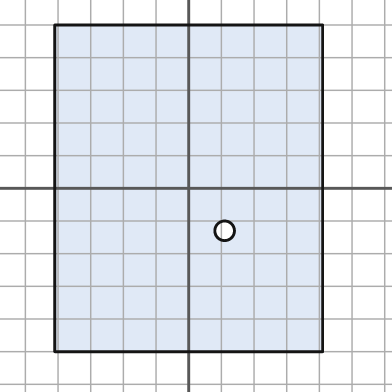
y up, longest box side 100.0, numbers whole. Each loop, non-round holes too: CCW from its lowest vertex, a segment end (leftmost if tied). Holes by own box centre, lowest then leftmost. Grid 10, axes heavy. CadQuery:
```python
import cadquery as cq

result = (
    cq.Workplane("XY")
    .moveTo(-41.0, -50.0)
    .lineTo(41.0, -50.0)
    .lineTo(41.0, 50.0)
    .lineTo(-41.0, 50.0)
    .close()
    .moveTo(11.0, -13.0)
    .circle(3.0)
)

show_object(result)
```